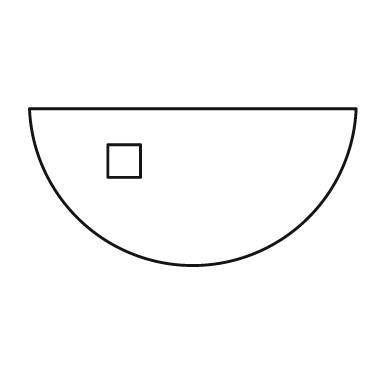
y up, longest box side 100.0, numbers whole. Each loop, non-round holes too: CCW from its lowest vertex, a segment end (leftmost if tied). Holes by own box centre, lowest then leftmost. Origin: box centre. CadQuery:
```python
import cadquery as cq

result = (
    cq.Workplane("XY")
    .moveTo(-50.0, 24.0)
    .threePointArc((0.0, -24.0), (50.0, 24.0))
    .close()
    .moveTo(-26.0, 3.0)
    .lineTo(-16.0, 3.0)
    .lineTo(-16.0, 13.0)
    .lineTo(-26.0, 13.0)
    .close()
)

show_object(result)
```